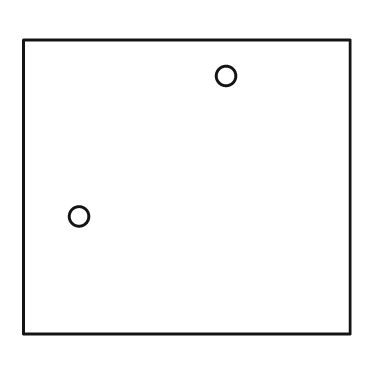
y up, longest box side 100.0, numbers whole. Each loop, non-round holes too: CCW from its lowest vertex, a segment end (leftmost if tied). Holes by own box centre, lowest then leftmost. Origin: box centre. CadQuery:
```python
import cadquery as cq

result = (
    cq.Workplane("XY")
    .moveTo(-50.0, -45.0)
    .lineTo(50.0, -45.0)
    .lineTo(50.0, 45.0)
    .lineTo(-50.0, 45.0)
    .close()
    .moveTo(-33.0, -9.0)
    .circle(3.0)
    .moveTo(12.0, 34.0)
    .circle(3.0)
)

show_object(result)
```